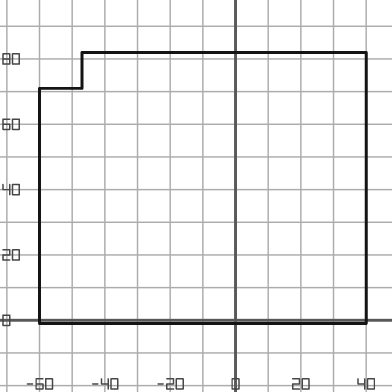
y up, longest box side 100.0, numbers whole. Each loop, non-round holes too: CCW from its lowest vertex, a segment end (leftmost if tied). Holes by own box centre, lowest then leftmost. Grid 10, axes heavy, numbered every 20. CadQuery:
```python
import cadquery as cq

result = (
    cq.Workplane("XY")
    .moveTo(-60.0, -1.0)
    .lineTo(40.0, -1.0)
    .lineTo(40.0, 82.0)
    .lineTo(-47.0, 82.0)
    .lineTo(-47.0, 71.0)
    .lineTo(-60.0, 71.0)
    .close()
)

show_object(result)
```